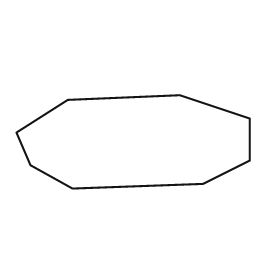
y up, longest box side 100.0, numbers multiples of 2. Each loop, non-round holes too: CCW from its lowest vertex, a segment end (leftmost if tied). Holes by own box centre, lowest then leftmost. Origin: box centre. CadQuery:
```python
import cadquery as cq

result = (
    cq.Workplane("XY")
    .moveTo(-26.0, -20.0)
    .lineTo(30.0, -18.0)
    .lineTo(50.0, -8.0)
    .lineTo(50.0, 10.0)
    .lineTo(20.0, 20.0)
    .lineTo(-28.0, 18.0)
    .lineTo(-50.0, 4.0)
    .lineTo(-44.0, -10.0)
    .close()
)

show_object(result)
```